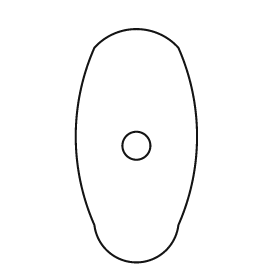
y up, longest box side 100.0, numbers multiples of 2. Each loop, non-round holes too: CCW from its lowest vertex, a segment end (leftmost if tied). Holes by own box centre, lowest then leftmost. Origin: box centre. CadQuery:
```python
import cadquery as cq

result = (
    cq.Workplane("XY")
    .moveTo(-18.0, -34.0)
    .threePointArc((0.0, -50.0), (18.0, -34.0))
    .threePointArc((26.0, 4.0), (18.0, 42.0))
    .threePointArc((0.0, 50.0), (-18.0, 42.0))
    .threePointArc((-26.0, 4.0), (-18.0, -34.0))
    .close()
    .moveTo(0.0, 0.0)
    .circle(6.0)
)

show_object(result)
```